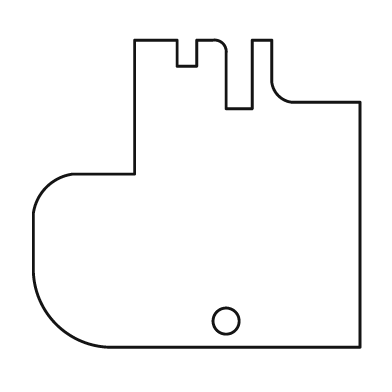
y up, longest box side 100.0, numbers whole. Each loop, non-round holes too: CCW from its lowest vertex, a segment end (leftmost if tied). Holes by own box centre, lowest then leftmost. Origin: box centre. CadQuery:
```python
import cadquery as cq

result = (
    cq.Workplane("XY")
    .moveTo(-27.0, -47.0)
    .lineTo(50.0, -47.0)
    .lineTo(50.0, 28.0)
    .lineTo(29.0, 28.0)
    .threePointArc((25.0, 30.0), (23.0, 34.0))
    .lineTo(23.0, 47.0)
    .lineTo(17.0, 47.0)
    .lineTo(17.0, 26.0)
    .lineTo(9.0, 26.0)
    .lineTo(9.0, 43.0)
    .threePointArc((8.0, 46.0), (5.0, 47.0))
    .lineTo(0.0, 47.0)
    .lineTo(0.0, 39.0)
    .lineTo(-6.0, 39.0)
    .lineTo(-6.0, 47.0)
    .lineTo(-19.0, 47.0)
    .lineTo(-19.0, 6.0)
    .lineTo(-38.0, 6.0)
    .threePointArc((-46.0, 2.0), (-50.0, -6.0))
    .lineTo(-50.0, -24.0)
    .threePointArc((-43.0, -40.0), (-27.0, -47.0))
    .close()
    .moveTo(9.0, -39.0)
    .circle(4.0)
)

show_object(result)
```